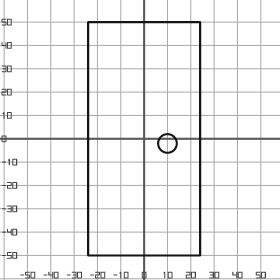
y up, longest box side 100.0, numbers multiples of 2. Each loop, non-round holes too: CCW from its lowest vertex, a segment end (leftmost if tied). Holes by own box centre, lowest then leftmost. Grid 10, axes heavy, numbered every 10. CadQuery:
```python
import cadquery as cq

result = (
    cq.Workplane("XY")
    .moveTo(-24.0, -50.0)
    .lineTo(24.0, -50.0)
    .lineTo(24.0, 50.0)
    .lineTo(-24.0, 50.0)
    .close()
    .moveTo(10.0, -2.0)
    .circle(4.0)
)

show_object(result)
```